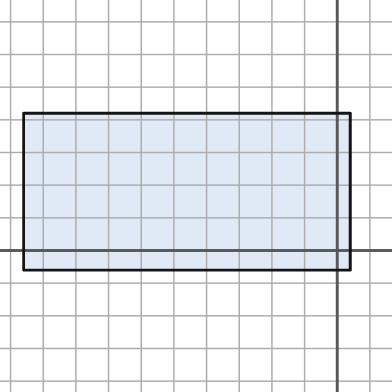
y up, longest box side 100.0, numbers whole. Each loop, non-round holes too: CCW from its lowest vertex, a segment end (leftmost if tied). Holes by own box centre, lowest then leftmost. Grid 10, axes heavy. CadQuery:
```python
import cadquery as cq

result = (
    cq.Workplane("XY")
    .moveTo(-96.0, -6.0)
    .lineTo(4.0, -6.0)
    .lineTo(4.0, 42.0)
    .lineTo(-96.0, 42.0)
    .close()
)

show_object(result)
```